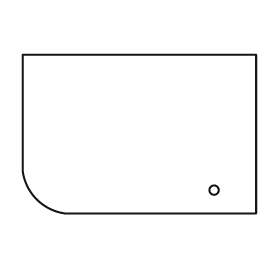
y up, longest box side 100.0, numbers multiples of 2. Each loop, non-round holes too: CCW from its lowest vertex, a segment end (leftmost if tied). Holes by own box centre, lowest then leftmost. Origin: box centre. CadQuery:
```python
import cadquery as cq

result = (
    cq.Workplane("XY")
    .moveTo(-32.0, -34.0)
    .lineTo(50.0, -34.0)
    .lineTo(50.0, 34.0)
    .lineTo(-50.0, 34.0)
    .lineTo(-50.0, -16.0)
    .threePointArc((-44.0, -28.0), (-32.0, -34.0))
    .close()
    .moveTo(32.0, -24.0)
    .circle(2.0)
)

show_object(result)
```